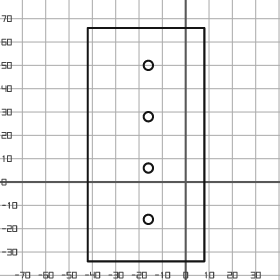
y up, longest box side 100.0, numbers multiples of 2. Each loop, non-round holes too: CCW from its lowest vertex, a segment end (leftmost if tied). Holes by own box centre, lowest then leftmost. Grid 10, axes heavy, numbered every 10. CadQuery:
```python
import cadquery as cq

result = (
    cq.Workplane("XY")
    .moveTo(-42.0, -34.0)
    .lineTo(8.0, -34.0)
    .lineTo(8.0, 66.0)
    .lineTo(-42.0, 66.0)
    .close()
    .moveTo(-16.0, -16.0)
    .circle(2.0)
    .moveTo(-16.0, 6.0)
    .circle(2.0)
    .moveTo(-16.0, 28.0)
    .circle(2.0)
    .moveTo(-16.0, 50.0)
    .circle(2.0)
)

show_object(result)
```